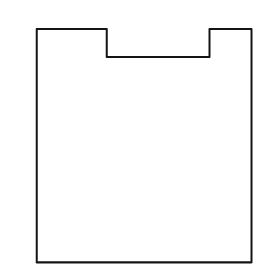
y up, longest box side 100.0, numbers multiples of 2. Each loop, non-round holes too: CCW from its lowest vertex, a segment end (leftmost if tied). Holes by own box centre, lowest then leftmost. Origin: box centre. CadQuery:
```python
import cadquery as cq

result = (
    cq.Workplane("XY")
    .moveTo(-46.0, -50.0)
    .lineTo(46.0, -50.0)
    .lineTo(46.0, 50.0)
    .lineTo(28.0, 50.0)
    .lineTo(28.0, 38.0)
    .lineTo(-16.0, 38.0)
    .lineTo(-16.0, 50.0)
    .lineTo(-46.0, 50.0)
    .close()
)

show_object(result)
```